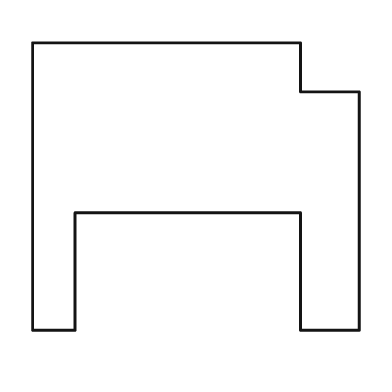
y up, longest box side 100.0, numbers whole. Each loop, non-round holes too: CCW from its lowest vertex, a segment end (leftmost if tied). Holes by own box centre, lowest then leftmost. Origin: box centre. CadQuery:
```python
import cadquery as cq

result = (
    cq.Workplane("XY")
    .moveTo(-50.0, -44.0)
    .lineTo(-37.0, -44.0)
    .lineTo(-37.0, -8.0)
    .lineTo(32.0, -8.0)
    .lineTo(32.0, -44.0)
    .lineTo(50.0, -44.0)
    .lineTo(50.0, 29.0)
    .lineTo(32.0, 29.0)
    .lineTo(32.0, 44.0)
    .lineTo(-50.0, 44.0)
    .close()
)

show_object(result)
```